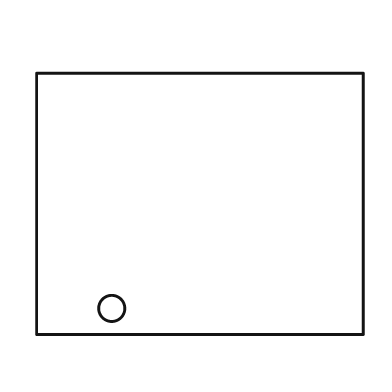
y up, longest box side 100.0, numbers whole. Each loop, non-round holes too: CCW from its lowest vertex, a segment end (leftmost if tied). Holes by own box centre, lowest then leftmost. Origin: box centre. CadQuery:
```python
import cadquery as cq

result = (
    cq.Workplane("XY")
    .moveTo(-50.0, -40.0)
    .lineTo(50.0, -40.0)
    .lineTo(50.0, 40.0)
    .lineTo(-50.0, 40.0)
    .close()
    .moveTo(-27.0, -32.0)
    .circle(4.0)
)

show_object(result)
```